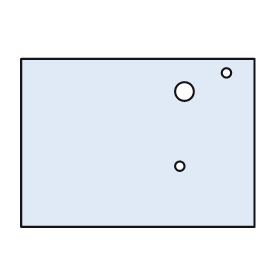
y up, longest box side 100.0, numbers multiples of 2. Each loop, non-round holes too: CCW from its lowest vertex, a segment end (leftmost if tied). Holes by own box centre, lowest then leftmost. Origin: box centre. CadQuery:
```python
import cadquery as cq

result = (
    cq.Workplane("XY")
    .moveTo(-50.0, -36.0)
    .lineTo(50.0, -36.0)
    .lineTo(50.0, 36.0)
    .lineTo(-50.0, 36.0)
    .close()
    .moveTo(18.0, -10.0)
    .circle(2.0)
    .moveTo(20.0, 22.0)
    .circle(4.0)
    .moveTo(38.0, 30.0)
    .circle(2.0)
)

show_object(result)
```